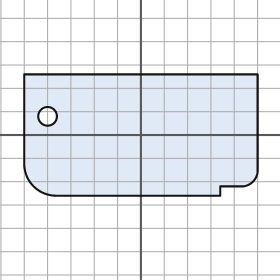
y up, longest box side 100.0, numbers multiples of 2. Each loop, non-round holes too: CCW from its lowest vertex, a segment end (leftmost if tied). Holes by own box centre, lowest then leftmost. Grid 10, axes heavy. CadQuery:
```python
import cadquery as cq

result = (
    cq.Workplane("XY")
    .moveTo(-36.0, -26.0)
    .lineTo(34.0, -26.0)
    .lineTo(34.0, -22.0)
    .lineTo(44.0, -22.0)
    .threePointArc((48.0, -20.0), (50.0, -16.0))
    .lineTo(50.0, 26.0)
    .lineTo(-50.0, 26.0)
    .lineTo(-50.0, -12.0)
    .threePointArc((-46.0, -22.0), (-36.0, -26.0))
    .close()
    .moveTo(-40.0, 8.0)
    .circle(4.0)
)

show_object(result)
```